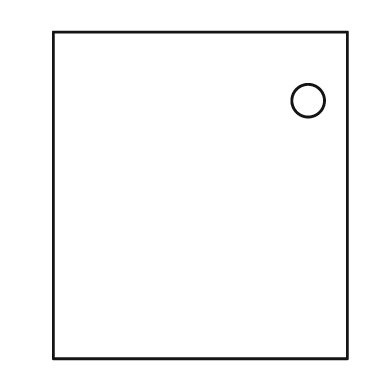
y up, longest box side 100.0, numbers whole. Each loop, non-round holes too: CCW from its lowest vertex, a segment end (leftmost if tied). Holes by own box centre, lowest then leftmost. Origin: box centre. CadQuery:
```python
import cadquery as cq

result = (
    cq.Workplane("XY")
    .moveTo(-45.0, -50.0)
    .lineTo(45.0, -50.0)
    .lineTo(45.0, 50.0)
    .lineTo(-45.0, 50.0)
    .close()
    .moveTo(33.0, 29.0)
    .circle(5.0)
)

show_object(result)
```